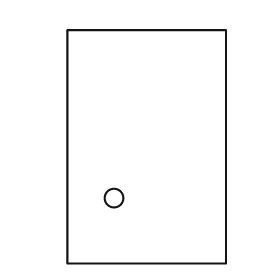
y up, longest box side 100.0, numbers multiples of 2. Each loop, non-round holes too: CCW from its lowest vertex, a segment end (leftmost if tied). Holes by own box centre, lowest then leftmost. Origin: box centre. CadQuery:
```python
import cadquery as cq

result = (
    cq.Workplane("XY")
    .moveTo(-34.0, -50.0)
    .lineTo(34.0, -50.0)
    .lineTo(34.0, 50.0)
    .lineTo(-34.0, 50.0)
    .close()
    .moveTo(-14.0, -22.0)
    .circle(4.0)
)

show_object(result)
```